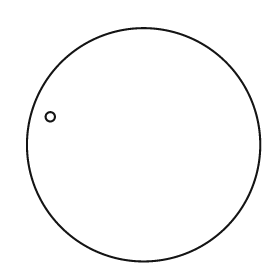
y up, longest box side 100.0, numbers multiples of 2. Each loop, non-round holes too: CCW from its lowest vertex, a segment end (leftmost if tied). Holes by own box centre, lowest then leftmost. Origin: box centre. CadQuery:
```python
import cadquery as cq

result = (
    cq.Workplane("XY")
    .moveTo(0.0, 0.0)
    .circle(50.0)
    .moveTo(-40.0, 12.0)
    .circle(2.0)
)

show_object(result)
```